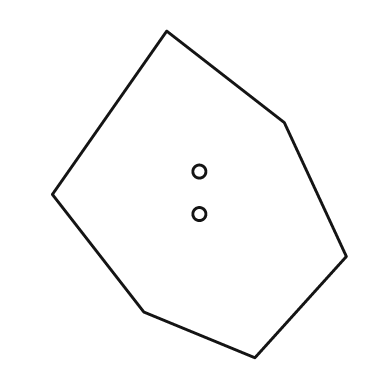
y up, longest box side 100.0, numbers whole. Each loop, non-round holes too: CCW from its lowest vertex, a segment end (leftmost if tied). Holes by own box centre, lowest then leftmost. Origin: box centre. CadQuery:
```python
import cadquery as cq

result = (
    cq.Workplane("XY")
    .moveTo(17.0, -50.0)
    .lineTo(45.0, -19.0)
    .lineTo(26.0, 22.0)
    .lineTo(-10.0, 50.0)
    .lineTo(-45.0, 0.0)
    .lineTo(-17.0, -36.0)
    .close()
    .moveTo(0.0, -6.0)
    .circle(2.0)
    .moveTo(0.0, 7.0)
    .circle(2.0)
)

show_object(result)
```